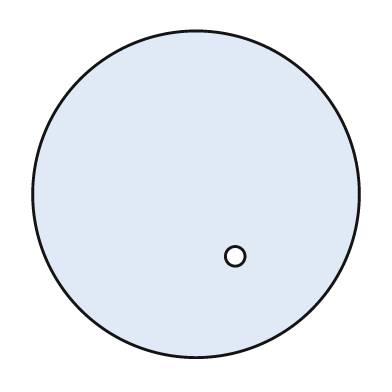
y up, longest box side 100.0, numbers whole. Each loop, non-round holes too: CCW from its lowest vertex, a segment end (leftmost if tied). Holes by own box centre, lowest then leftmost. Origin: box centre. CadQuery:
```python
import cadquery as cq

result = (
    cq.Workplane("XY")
    .moveTo(0.0, 0.0)
    .circle(50.0)
    .moveTo(12.0, -19.0)
    .circle(3.0)
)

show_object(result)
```